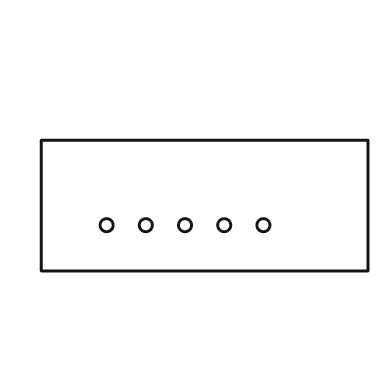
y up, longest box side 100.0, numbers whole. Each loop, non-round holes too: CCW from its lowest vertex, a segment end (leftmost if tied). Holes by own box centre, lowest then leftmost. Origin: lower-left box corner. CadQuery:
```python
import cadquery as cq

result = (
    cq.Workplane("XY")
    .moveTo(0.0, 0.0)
    .lineTo(100.0, 0.0)
    .lineTo(100.0, 40.0)
    .lineTo(0.0, 40.0)
    .close()
    .moveTo(20.0, 14.0)
    .circle(2.0)
    .moveTo(32.0, 14.0)
    .circle(2.0)
    .moveTo(44.0, 14.0)
    .circle(2.0)
    .moveTo(56.0, 14.0)
    .circle(2.0)
    .moveTo(68.0, 14.0)
    .circle(2.0)
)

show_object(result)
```